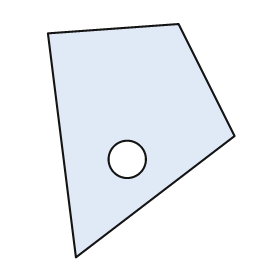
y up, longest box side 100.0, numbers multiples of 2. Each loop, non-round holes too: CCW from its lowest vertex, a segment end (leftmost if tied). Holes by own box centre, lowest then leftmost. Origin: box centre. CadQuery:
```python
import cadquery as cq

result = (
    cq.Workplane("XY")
    .moveTo(-28.0, -50.0)
    .lineTo(40.0, 2.0)
    .lineTo(16.0, 50.0)
    .lineTo(-40.0, 46.0)
    .close()
    .moveTo(-6.0, -8.0)
    .circle(8.0)
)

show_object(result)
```